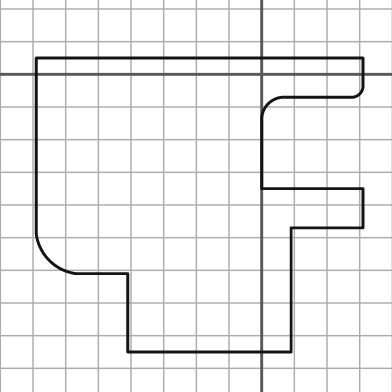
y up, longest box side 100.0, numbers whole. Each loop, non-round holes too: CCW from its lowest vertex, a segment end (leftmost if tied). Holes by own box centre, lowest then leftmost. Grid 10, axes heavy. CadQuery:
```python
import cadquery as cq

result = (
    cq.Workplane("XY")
    .moveTo(-41.0, -85.0)
    .lineTo(9.0, -85.0)
    .lineTo(9.0, -47.0)
    .lineTo(31.0, -47.0)
    .lineTo(31.0, -35.0)
    .lineTo(0.0, -35.0)
    .lineTo(0.0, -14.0)
    .threePointArc((2.0, -9.0), (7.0, -7.0))
    .lineTo(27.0, -7.0)
    .threePointArc((30.0, -6.0), (31.0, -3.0))
    .lineTo(31.0, 5.0)
    .lineTo(-69.0, 5.0)
    .lineTo(-69.0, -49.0)
    .threePointArc((-65.0, -57.0), (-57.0, -61.0))
    .lineTo(-41.0, -61.0)
    .close()
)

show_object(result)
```